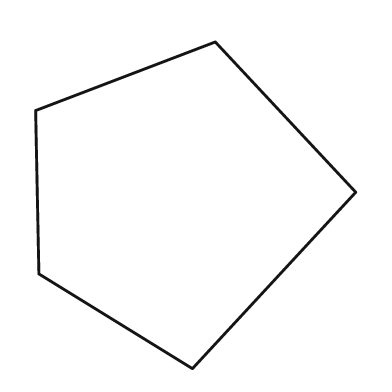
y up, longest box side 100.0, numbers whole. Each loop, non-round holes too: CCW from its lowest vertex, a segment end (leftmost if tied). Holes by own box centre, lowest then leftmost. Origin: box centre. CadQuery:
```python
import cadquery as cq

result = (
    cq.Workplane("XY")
    .moveTo(-1.0, -50.0)
    .lineTo(49.0, 4.0)
    .lineTo(6.0, 50.0)
    .lineTo(-49.0, 29.0)
    .lineTo(-48.0, -21.0)
    .close()
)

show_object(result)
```